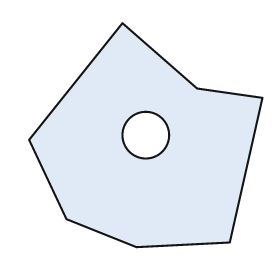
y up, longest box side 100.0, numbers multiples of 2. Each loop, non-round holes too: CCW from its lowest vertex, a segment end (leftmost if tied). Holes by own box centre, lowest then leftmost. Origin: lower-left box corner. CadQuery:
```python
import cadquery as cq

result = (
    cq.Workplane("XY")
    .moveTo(46.0, 0.0)
    .lineTo(86.0, 2.0)
    .lineTo(100.0, 64.0)
    .lineTo(72.0, 68.0)
    .lineTo(40.0, 96.0)
    .lineTo(0.0, 46.0)
    .lineTo(16.0, 12.0)
    .close()
    .moveTo(50.0, 48.0)
    .circle(10.0)
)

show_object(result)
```